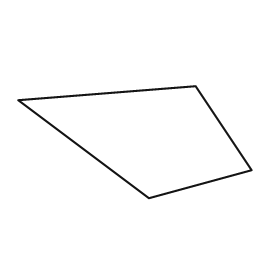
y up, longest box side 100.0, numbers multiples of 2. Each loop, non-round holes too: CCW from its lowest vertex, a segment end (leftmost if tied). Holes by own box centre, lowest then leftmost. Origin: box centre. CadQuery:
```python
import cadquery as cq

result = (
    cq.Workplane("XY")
    .moveTo(6.0, -24.0)
    .lineTo(50.0, -12.0)
    .lineTo(26.0, 24.0)
    .lineTo(-50.0, 18.0)
    .close()
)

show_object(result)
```